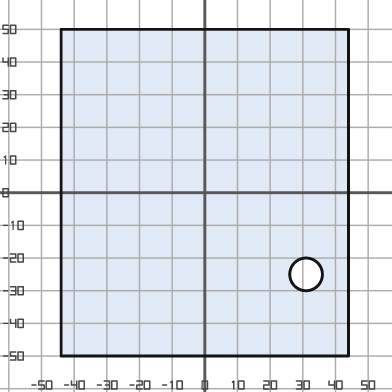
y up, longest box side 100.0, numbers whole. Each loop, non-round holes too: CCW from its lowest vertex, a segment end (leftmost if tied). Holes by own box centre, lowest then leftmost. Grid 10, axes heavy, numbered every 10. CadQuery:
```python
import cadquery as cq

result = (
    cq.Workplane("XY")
    .moveTo(-44.0, -50.0)
    .lineTo(44.0, -50.0)
    .lineTo(44.0, 50.0)
    .lineTo(-44.0, 50.0)
    .close()
    .moveTo(31.0, -25.0)
    .circle(5.0)
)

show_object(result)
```